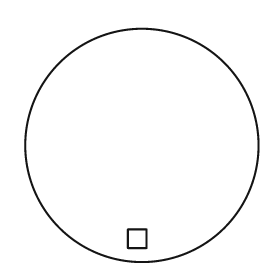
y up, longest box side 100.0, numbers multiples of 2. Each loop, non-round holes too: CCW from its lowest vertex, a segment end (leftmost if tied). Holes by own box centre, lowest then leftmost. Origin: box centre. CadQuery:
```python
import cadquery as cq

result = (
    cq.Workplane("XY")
    .moveTo(0.0, 0.0)
    .circle(50.0)
    .moveTo(-6.0, -44.0)
    .lineTo(2.0, -44.0)
    .lineTo(2.0, -36.0)
    .lineTo(-6.0, -36.0)
    .close()
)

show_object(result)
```